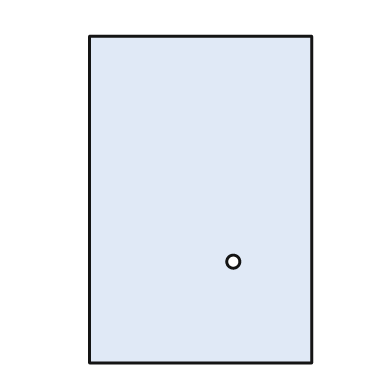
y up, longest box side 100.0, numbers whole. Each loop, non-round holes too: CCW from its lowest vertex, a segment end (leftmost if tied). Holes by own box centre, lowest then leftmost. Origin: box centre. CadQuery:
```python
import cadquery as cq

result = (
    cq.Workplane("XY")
    .moveTo(-34.0, -50.0)
    .lineTo(34.0, -50.0)
    .lineTo(34.0, 50.0)
    .lineTo(-34.0, 50.0)
    .close()
    .moveTo(10.0, -19.0)
    .circle(2.0)
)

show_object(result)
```